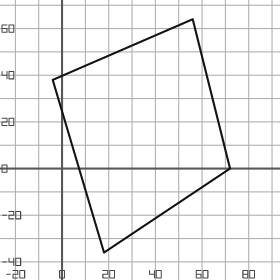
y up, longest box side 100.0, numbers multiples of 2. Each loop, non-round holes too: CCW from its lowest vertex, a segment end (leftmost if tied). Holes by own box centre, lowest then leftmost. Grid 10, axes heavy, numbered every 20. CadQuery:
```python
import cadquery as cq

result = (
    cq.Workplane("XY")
    .moveTo(18.0, -36.0)
    .lineTo(72.0, 0.0)
    .lineTo(56.0, 64.0)
    .lineTo(-4.0, 38.0)
    .close()
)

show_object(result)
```